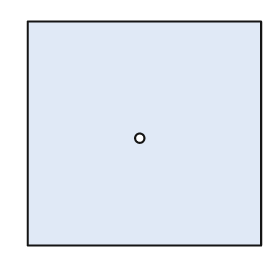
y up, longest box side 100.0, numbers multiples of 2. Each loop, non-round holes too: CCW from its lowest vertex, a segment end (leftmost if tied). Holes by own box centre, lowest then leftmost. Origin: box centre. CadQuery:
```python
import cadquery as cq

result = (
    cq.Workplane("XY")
    .moveTo(-50.0, -48.0)
    .lineTo(50.0, -48.0)
    .lineTo(50.0, 48.0)
    .lineTo(-50.0, 48.0)
    .close()
    .moveTo(-2.0, -2.0)
    .circle(2.0)
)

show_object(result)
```